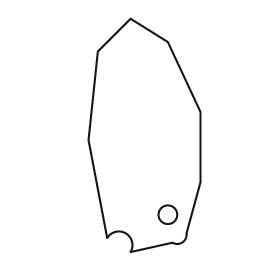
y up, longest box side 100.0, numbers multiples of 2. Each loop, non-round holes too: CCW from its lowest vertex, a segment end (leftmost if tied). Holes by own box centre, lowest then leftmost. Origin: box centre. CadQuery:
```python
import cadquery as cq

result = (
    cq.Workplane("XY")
    .moveTo(-6.0, -50.0)
    .lineTo(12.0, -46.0)
    .threePointArc((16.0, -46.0), (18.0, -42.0))
    .lineTo(24.0, -20.0)
    .lineTo(24.0, 10.0)
    .lineTo(10.0, 40.0)
    .lineTo(-6.0, 50.0)
    .lineTo(-20.0, 36.0)
    .lineTo(-24.0, -2.0)
    .lineTo(-16.0, -44.0)
    .threePointArc((-8.0, -42.0), (-6.0, -50.0))
    .close()
    .moveTo(10.0, -34.0)
    .circle(4.0)
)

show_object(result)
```